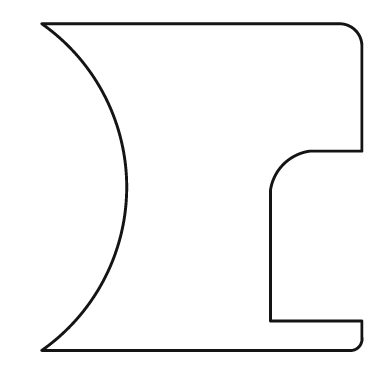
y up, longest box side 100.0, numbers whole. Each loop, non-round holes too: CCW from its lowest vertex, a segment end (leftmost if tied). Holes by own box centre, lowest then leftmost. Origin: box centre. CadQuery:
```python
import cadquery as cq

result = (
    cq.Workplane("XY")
    .moveTo(-49.0, -50.0)
    .lineTo(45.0, -50.0)
    .threePointArc((48.0, -49.0), (49.0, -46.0))
    .lineTo(49.0, -41.0)
    .lineTo(21.0, -41.0)
    .lineTo(21.0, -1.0)
    .threePointArc((25.0, 7.0), (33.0, 11.0))
    .lineTo(49.0, 11.0)
    .lineTo(49.0, 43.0)
    .threePointArc((47.0, 48.0), (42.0, 50.0))
    .lineTo(-49.0, 50.0)
    .threePointArc((-23.0, 0.0), (-49.0, -50.0))
    .close()
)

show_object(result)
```